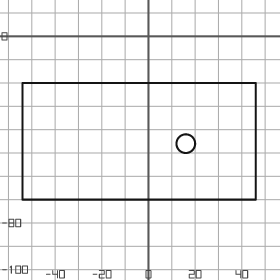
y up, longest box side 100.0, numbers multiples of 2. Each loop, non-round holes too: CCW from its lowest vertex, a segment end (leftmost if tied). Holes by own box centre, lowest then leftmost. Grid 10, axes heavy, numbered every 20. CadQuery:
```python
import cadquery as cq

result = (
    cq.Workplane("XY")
    .moveTo(-54.0, -70.0)
    .lineTo(46.0, -70.0)
    .lineTo(46.0, -20.0)
    .lineTo(-54.0, -20.0)
    .close()
    .moveTo(16.0, -46.0)
    .circle(4.0)
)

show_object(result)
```